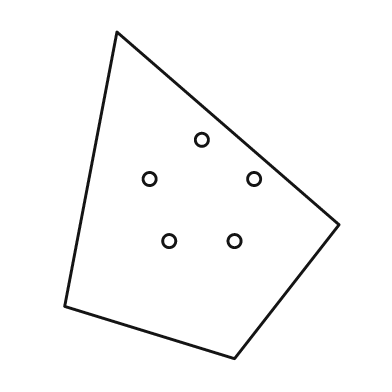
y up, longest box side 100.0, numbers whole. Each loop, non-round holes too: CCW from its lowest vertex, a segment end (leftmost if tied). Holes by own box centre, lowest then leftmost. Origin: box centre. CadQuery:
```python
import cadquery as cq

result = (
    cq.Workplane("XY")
    .moveTo(10.0, -50.0)
    .lineTo(42.0, -9.0)
    .lineTo(-26.0, 50.0)
    .lineTo(-42.0, -34.0)
    .close()
    .moveTo(-10.0, -14.0)
    .circle(2.0)
    .moveTo(10.0, -14.0)
    .circle(2.0)
    .moveTo(-16.0, 5.0)
    .circle(2.0)
    .moveTo(16.0, 5.0)
    .circle(2.0)
    .moveTo(0.0, 17.0)
    .circle(2.0)
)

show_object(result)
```